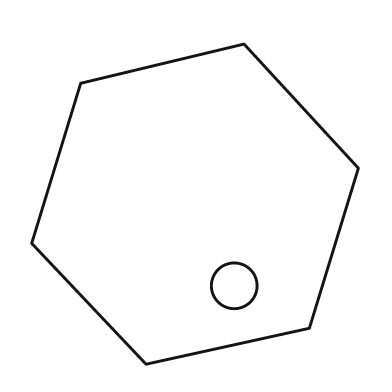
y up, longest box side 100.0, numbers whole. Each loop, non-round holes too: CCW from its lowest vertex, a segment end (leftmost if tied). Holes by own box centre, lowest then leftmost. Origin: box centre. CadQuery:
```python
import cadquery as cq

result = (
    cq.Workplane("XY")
    .moveTo(-15.0, -49.0)
    .lineTo(35.0, -38.0)
    .lineTo(50.0, 11.0)
    .lineTo(15.0, 49.0)
    .lineTo(-35.0, 37.0)
    .lineTo(-50.0, -12.0)
    .close()
    .moveTo(12.0, -25.0)
    .circle(7.0)
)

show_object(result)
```